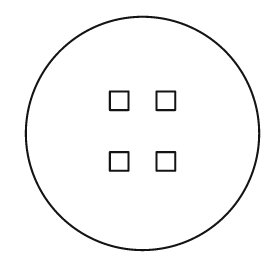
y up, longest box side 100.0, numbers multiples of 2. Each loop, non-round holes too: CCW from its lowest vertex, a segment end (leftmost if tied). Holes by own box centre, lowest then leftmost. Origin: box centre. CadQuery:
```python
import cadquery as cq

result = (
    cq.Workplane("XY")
    .moveTo(0.0, 0.0)
    .circle(50.0)
    .moveTo(-14.0, -16.0)
    .lineTo(-6.0, -16.0)
    .lineTo(-6.0, -8.0)
    .lineTo(-14.0, -8.0)
    .close()
    .moveTo(6.0, -16.0)
    .lineTo(14.0, -16.0)
    .lineTo(14.0, -8.0)
    .lineTo(6.0, -8.0)
    .close()
    .moveTo(-14.0, 10.0)
    .lineTo(-6.0, 10.0)
    .lineTo(-6.0, 18.0)
    .lineTo(-14.0, 18.0)
    .close()
    .moveTo(6.0, 10.0)
    .lineTo(14.0, 10.0)
    .lineTo(14.0, 18.0)
    .lineTo(6.0, 18.0)
    .close()
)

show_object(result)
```